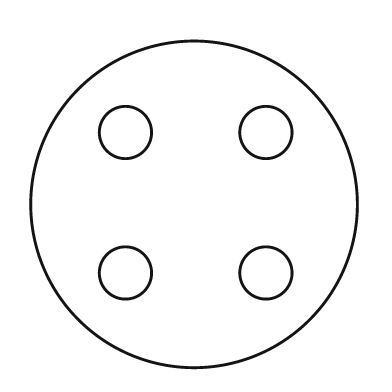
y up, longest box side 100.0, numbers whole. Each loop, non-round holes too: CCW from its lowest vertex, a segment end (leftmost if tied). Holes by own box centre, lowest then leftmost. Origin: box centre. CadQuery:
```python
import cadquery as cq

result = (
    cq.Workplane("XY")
    .moveTo(0.0, 0.0)
    .circle(50.0)
    .moveTo(-21.0, -21.0)
    .circle(8.0)
    .moveTo(22.0, -21.0)
    .circle(8.0)
    .moveTo(-21.0, 22.0)
    .circle(8.0)
    .moveTo(22.0, 22.0)
    .circle(8.0)
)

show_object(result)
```